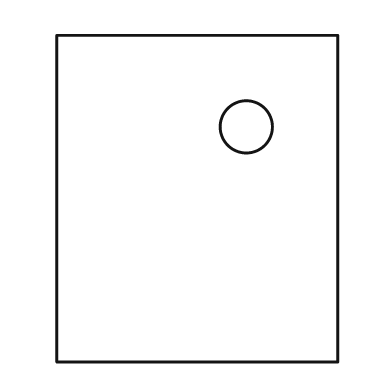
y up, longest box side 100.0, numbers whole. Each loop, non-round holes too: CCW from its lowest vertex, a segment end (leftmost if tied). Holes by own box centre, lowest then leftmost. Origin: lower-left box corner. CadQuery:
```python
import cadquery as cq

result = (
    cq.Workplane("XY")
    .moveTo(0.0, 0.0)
    .lineTo(86.0, 0.0)
    .lineTo(86.0, 100.0)
    .lineTo(0.0, 100.0)
    .close()
    .moveTo(58.0, 72.0)
    .circle(8.0)
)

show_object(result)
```